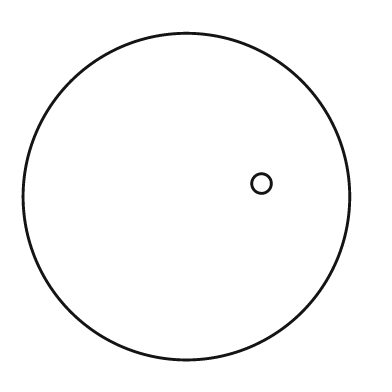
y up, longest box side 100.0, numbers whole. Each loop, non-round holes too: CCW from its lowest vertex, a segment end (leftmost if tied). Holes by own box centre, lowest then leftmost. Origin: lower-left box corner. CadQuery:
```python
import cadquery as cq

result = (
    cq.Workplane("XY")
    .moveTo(50.0, 50.0)
    .circle(50.0)
    .moveTo(73.0, 54.0)
    .circle(3.0)
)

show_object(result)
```